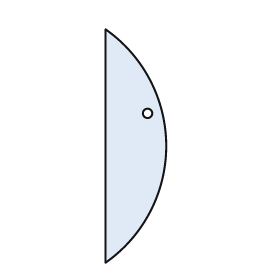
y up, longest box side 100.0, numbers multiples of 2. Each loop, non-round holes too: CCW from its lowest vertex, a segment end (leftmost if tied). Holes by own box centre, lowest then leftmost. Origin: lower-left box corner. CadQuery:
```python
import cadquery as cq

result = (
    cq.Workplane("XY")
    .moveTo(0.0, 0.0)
    .threePointArc((26.0, 50.0), (0.0, 100.0))
    .close()
    .moveTo(18.0, 64.0)
    .circle(2.0)
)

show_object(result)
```